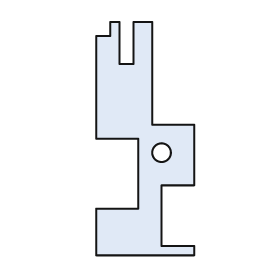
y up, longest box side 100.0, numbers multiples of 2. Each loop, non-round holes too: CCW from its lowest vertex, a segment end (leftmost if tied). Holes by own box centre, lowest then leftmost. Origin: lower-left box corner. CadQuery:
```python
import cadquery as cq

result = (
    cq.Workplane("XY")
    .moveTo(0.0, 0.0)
    .lineTo(42.0, 0.0)
    .lineTo(42.0, 4.0)
    .lineTo(28.0, 4.0)
    .lineTo(28.0, 30.0)
    .lineTo(42.0, 30.0)
    .lineTo(42.0, 56.0)
    .lineTo(24.0, 56.0)
    .lineTo(24.0, 100.0)
    .lineTo(16.0, 100.0)
    .lineTo(16.0, 82.0)
    .lineTo(10.0, 82.0)
    .lineTo(10.0, 100.0)
    .lineTo(6.0, 100.0)
    .lineTo(6.0, 94.0)
    .lineTo(0.0, 94.0)
    .lineTo(0.0, 50.0)
    .lineTo(18.0, 50.0)
    .lineTo(18.0, 20.0)
    .lineTo(0.0, 20.0)
    .close()
    .moveTo(28.0, 44.0)
    .circle(4.0)
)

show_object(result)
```